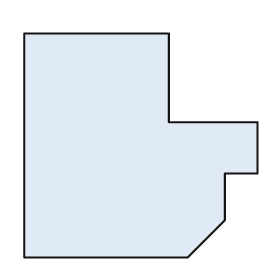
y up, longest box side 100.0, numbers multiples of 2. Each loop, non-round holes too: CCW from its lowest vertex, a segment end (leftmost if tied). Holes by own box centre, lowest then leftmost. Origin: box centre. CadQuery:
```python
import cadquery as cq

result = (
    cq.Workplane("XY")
    .moveTo(-50.0, -48.0)
    .lineTo(20.0, -48.0)
    .lineTo(36.0, -32.0)
    .lineTo(36.0, -12.0)
    .lineTo(50.0, -12.0)
    .lineTo(50.0, 10.0)
    .lineTo(12.0, 10.0)
    .lineTo(12.0, 48.0)
    .lineTo(-50.0, 48.0)
    .close()
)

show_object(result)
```